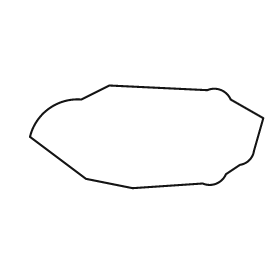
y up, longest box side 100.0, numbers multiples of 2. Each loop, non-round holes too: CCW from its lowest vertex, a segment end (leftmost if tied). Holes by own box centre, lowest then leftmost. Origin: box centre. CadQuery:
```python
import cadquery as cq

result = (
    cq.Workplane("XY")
    .moveTo(-6.0, -22.0)
    .lineTo(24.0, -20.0)
    .threePointArc((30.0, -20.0), (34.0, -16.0))
    .lineTo(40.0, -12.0)
    .threePointArc((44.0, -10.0), (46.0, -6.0))
    .lineTo(50.0, 8.0)
    .lineTo(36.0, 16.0)
    .threePointArc((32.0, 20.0), (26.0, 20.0))
    .lineTo(-16.0, 22.0)
    .lineTo(-28.0, 16.0)
    .threePointArc((-42.0, 12.0), (-50.0, 0.0))
    .lineTo(-26.0, -18.0)
    .close()
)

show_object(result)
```